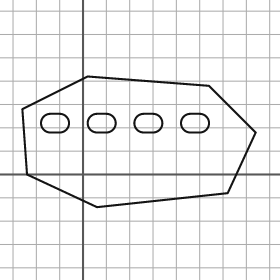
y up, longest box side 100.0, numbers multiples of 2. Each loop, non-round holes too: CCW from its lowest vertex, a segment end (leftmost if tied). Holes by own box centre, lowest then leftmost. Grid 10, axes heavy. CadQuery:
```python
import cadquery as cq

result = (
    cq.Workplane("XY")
    .moveTo(6.0, -14.0)
    .lineTo(62.0, -8.0)
    .lineTo(74.0, 18.0)
    .lineTo(54.0, 38.0)
    .lineTo(2.0, 42.0)
    .lineTo(-26.0, 28.0)
    .lineTo(-24.0, 0.0)
    .close()
    .moveTo(-14.0, 18.0)
    .lineTo(-10.0, 18.0)
    .threePointArc((-6.0, 22.0), (-10.0, 26.0))
    .lineTo(-14.0, 26.0)
    .threePointArc((-18.0, 22.0), (-14.0, 18.0))
    .close()
    .moveTo(6.0, 18.0)
    .lineTo(10.0, 18.0)
    .threePointArc((14.0, 22.0), (10.0, 26.0))
    .lineTo(6.0, 26.0)
    .threePointArc((2.0, 22.0), (6.0, 18.0))
    .close()
    .moveTo(26.0, 18.0)
    .lineTo(30.0, 18.0)
    .threePointArc((34.0, 22.0), (30.0, 26.0))
    .lineTo(26.0, 26.0)
    .threePointArc((22.0, 22.0), (26.0, 18.0))
    .close()
    .moveTo(46.0, 18.0)
    .lineTo(50.0, 18.0)
    .threePointArc((54.0, 22.0), (50.0, 26.0))
    .lineTo(46.0, 26.0)
    .threePointArc((42.0, 22.0), (46.0, 18.0))
    .close()
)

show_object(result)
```